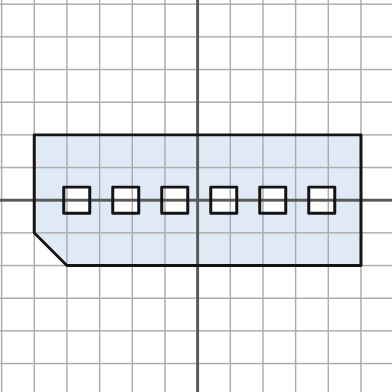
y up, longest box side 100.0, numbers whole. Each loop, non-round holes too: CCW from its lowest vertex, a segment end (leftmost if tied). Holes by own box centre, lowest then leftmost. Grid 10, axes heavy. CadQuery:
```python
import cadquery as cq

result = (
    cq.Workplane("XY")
    .moveTo(-40.0, -20.0)
    .lineTo(50.0, -20.0)
    .lineTo(50.0, 20.0)
    .lineTo(-50.0, 20.0)
    .lineTo(-50.0, -10.0)
    .close()
    .moveTo(-41.0, -4.0)
    .lineTo(-33.0, -4.0)
    .lineTo(-33.0, 4.0)
    .lineTo(-41.0, 4.0)
    .close()
    .moveTo(-26.0, -4.0)
    .lineTo(-18.0, -4.0)
    .lineTo(-18.0, 4.0)
    .lineTo(-26.0, 4.0)
    .close()
    .moveTo(-11.0, -4.0)
    .lineTo(-3.0, -4.0)
    .lineTo(-3.0, 4.0)
    .lineTo(-11.0, 4.0)
    .close()
    .moveTo(4.0, -4.0)
    .lineTo(12.0, -4.0)
    .lineTo(12.0, 4.0)
    .lineTo(4.0, 4.0)
    .close()
    .moveTo(19.0, -4.0)
    .lineTo(27.0, -4.0)
    .lineTo(27.0, 4.0)
    .lineTo(19.0, 4.0)
    .close()
    .moveTo(34.0, -4.0)
    .lineTo(42.0, -4.0)
    .lineTo(42.0, 4.0)
    .lineTo(34.0, 4.0)
    .close()
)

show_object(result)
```